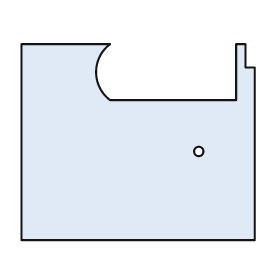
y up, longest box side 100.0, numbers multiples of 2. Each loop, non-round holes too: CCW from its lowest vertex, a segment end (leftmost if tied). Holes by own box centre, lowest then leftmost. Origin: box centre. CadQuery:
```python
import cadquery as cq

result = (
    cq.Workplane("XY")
    .moveTo(-50.0, -42.0)
    .lineTo(50.0, -42.0)
    .lineTo(50.0, 32.0)
    .lineTo(46.0, 32.0)
    .lineTo(46.0, 42.0)
    .lineTo(42.0, 42.0)
    .lineTo(42.0, 18.0)
    .lineTo(-12.0, 18.0)
    .threePointArc((-18.0, 30.0), (-12.0, 42.0))
    .lineTo(-50.0, 42.0)
    .close()
    .moveTo(26.0, -4.0)
    .circle(2.0)
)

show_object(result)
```